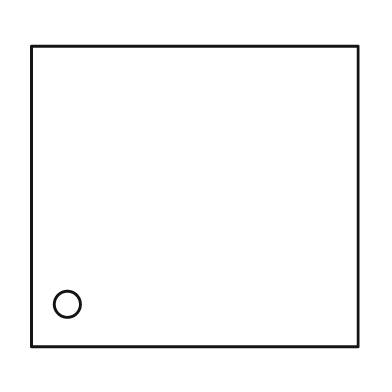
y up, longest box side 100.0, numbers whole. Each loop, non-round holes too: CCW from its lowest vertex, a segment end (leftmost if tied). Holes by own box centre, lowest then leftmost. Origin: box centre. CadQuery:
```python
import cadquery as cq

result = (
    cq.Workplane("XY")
    .moveTo(-50.0, -46.0)
    .lineTo(50.0, -46.0)
    .lineTo(50.0, 46.0)
    .lineTo(-50.0, 46.0)
    .close()
    .moveTo(-39.0, -33.0)
    .circle(4.0)
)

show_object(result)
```